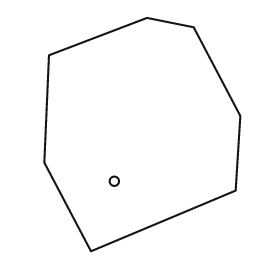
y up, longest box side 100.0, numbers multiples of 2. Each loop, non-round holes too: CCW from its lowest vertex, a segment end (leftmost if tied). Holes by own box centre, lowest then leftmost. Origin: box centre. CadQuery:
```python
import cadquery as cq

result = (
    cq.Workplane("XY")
    .moveTo(-22.0, -50.0)
    .lineTo(40.0, -24.0)
    .lineTo(42.0, 8.0)
    .lineTo(22.0, 46.0)
    .lineTo(2.0, 50.0)
    .lineTo(-40.0, 34.0)
    .lineTo(-42.0, -12.0)
    .close()
    .moveTo(-12.0, -20.0)
    .circle(2.0)
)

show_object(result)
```